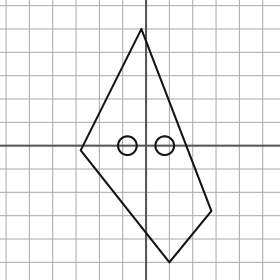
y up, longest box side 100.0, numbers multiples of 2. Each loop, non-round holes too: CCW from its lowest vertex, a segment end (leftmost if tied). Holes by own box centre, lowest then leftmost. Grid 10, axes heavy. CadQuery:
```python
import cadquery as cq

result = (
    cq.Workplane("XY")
    .moveTo(10.0, -50.0)
    .lineTo(28.0, -28.0)
    .lineTo(-2.0, 50.0)
    .lineTo(-28.0, -2.0)
    .close()
    .moveTo(-8.0, 0.0)
    .circle(4.0)
    .moveTo(8.0, 0.0)
    .circle(4.0)
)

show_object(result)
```